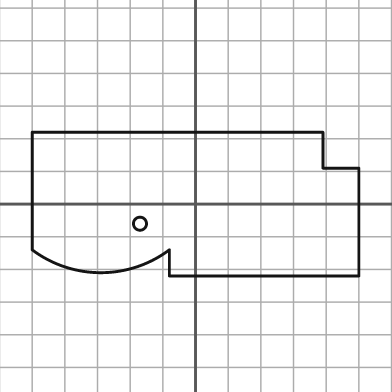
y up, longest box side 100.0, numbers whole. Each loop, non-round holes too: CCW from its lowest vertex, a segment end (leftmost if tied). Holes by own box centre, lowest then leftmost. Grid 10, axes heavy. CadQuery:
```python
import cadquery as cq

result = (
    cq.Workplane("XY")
    .moveTo(-8.0, -22.0)
    .lineTo(50.0, -22.0)
    .lineTo(50.0, 11.0)
    .lineTo(39.0, 11.0)
    .lineTo(39.0, 22.0)
    .lineTo(-50.0, 22.0)
    .lineTo(-50.0, -14.0)
    .threePointArc((-29.0, -21.0), (-8.0, -14.0))
    .close()
    .moveTo(-17.0, -6.0)
    .circle(2.0)
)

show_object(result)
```